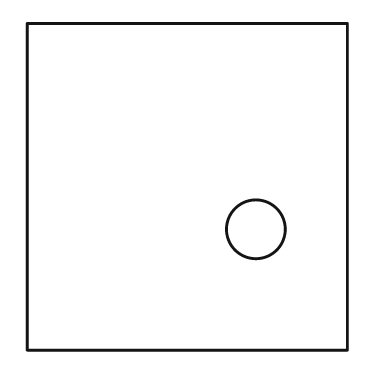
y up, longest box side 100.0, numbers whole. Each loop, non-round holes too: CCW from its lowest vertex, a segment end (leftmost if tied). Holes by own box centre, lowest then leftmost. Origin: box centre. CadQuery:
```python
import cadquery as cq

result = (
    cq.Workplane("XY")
    .moveTo(-49.0, -50.0)
    .lineTo(49.0, -50.0)
    .lineTo(49.0, 50.0)
    .lineTo(-49.0, 50.0)
    .close()
    .moveTo(21.0, -13.0)
    .circle(9.0)
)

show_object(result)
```